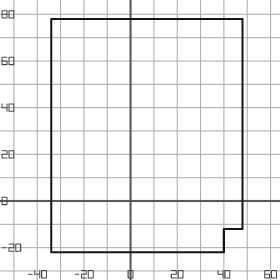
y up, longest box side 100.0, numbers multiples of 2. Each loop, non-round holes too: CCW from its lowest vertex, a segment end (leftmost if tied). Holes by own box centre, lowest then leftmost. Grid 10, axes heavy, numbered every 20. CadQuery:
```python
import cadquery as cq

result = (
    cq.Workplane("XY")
    .moveTo(-34.0, -22.0)
    .lineTo(40.0, -22.0)
    .lineTo(40.0, -12.0)
    .lineTo(48.0, -12.0)
    .lineTo(48.0, 78.0)
    .lineTo(-34.0, 78.0)
    .close()
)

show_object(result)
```